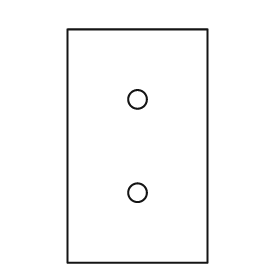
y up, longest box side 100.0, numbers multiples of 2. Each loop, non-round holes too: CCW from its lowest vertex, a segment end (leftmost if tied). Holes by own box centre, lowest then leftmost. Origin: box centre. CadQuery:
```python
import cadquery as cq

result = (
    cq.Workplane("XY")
    .moveTo(-30.0, -50.0)
    .lineTo(30.0, -50.0)
    .lineTo(30.0, 50.0)
    .lineTo(-30.0, 50.0)
    .close()
    .moveTo(0.0, -20.0)
    .circle(4.0)
    .moveTo(0.0, 20.0)
    .circle(4.0)
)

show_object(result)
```